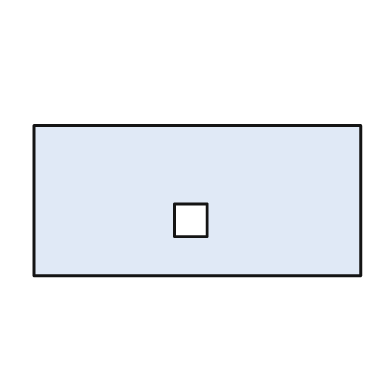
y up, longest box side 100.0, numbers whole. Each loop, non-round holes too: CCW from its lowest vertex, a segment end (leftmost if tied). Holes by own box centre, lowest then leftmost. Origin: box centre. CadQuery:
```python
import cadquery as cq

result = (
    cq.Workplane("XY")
    .moveTo(-50.0, -23.0)
    .lineTo(50.0, -23.0)
    .lineTo(50.0, 23.0)
    .lineTo(-50.0, 23.0)
    .close()
    .moveTo(-7.0, -11.0)
    .lineTo(3.0, -11.0)
    .lineTo(3.0, -1.0)
    .lineTo(-7.0, -1.0)
    .close()
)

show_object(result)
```